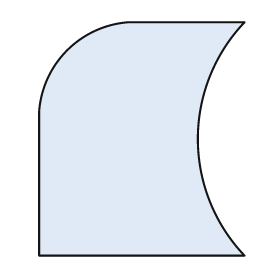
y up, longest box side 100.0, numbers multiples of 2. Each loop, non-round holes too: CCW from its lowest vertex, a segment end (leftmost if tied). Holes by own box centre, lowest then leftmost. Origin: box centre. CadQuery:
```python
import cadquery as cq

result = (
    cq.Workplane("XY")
    .moveTo(-44.0, -50.0)
    .lineTo(44.0, -50.0)
    .threePointArc((24.0, 0.0), (44.0, 50.0))
    .lineTo(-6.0, 50.0)
    .threePointArc((-32.0, 38.0), (-44.0, 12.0))
    .close()
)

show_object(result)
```